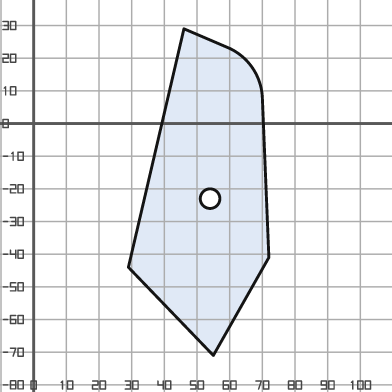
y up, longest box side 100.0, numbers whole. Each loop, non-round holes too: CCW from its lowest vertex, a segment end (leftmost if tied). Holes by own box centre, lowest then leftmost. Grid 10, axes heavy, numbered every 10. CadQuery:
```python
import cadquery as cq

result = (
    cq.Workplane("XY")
    .moveTo(55.0, -71.0)
    .lineTo(72.0, -41.0)
    .lineTo(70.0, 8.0)
    .threePointArc((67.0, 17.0), (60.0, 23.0))
    .lineTo(46.0, 29.0)
    .lineTo(29.0, -44.0)
    .close()
    .moveTo(54.0, -23.0)
    .circle(3.0)
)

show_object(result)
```